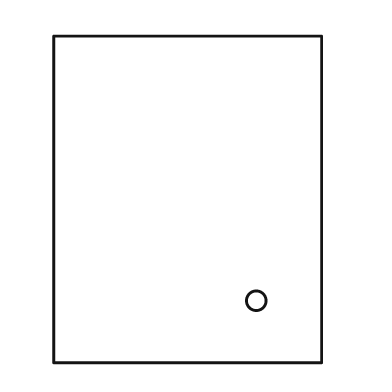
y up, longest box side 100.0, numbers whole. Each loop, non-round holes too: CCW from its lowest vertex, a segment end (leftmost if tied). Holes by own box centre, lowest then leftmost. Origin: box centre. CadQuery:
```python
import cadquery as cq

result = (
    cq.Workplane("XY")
    .moveTo(-41.0, -50.0)
    .lineTo(41.0, -50.0)
    .lineTo(41.0, 50.0)
    .lineTo(-41.0, 50.0)
    .close()
    .moveTo(21.0, -31.0)
    .circle(3.0)
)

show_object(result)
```